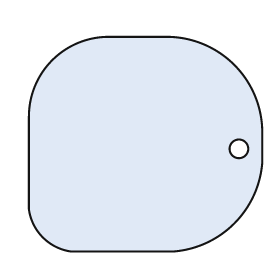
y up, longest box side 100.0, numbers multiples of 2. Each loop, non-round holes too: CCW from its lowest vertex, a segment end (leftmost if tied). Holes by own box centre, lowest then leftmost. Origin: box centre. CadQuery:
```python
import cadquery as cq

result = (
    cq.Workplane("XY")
    .moveTo(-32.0, -46.0)
    .lineTo(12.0, -46.0)
    .threePointArc((38.0, -34.0), (50.0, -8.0))
    .lineTo(50.0, 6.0)
    .threePointArc((38.0, 34.0), (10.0, 46.0))
    .lineTo(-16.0, 46.0)
    .threePointArc((-40.0, 36.0), (-50.0, 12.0))
    .lineTo(-50.0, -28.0)
    .threePointArc((-44.0, -40.0), (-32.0, -46.0))
    .close()
    .moveTo(40.0, -2.0)
    .circle(4.0)
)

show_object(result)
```